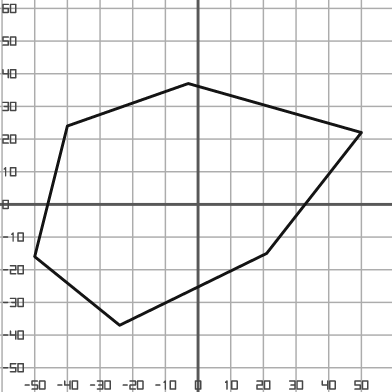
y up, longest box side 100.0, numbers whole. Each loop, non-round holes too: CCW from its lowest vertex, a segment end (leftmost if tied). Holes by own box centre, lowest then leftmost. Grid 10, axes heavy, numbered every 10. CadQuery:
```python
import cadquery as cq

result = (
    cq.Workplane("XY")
    .moveTo(-24.0, -37.0)
    .lineTo(21.0, -15.0)
    .lineTo(50.0, 22.0)
    .lineTo(-3.0, 37.0)
    .lineTo(-40.0, 24.0)
    .lineTo(-50.0, -16.0)
    .close()
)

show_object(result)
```